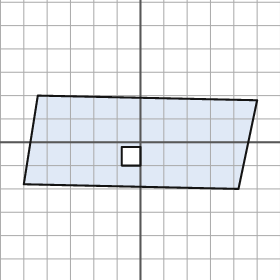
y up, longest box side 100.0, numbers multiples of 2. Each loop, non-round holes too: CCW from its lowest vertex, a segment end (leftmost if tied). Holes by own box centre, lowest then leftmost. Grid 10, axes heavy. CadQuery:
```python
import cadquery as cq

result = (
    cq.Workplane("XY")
    .moveTo(42.0, -20.0)
    .lineTo(50.0, 18.0)
    .lineTo(-44.0, 20.0)
    .lineTo(-50.0, -18.0)
    .close()
    .moveTo(-8.0, -10.0)
    .lineTo(0.0, -10.0)
    .lineTo(0.0, -2.0)
    .lineTo(-8.0, -2.0)
    .close()
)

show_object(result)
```